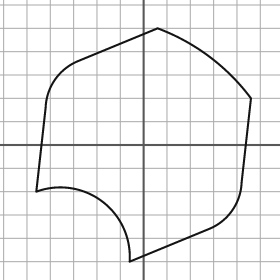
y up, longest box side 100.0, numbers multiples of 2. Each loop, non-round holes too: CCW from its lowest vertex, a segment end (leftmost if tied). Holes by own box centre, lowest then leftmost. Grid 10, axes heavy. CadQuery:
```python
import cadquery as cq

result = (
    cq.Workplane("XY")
    .moveTo(-6.0, -50.0)
    .lineTo(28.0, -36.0)
    .threePointArc((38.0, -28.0), (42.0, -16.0))
    .lineTo(46.0, 20.0)
    .threePointArc((28.0, 38.0), (6.0, 50.0))
    .lineTo(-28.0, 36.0)
    .threePointArc((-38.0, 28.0), (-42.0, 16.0))
    .lineTo(-46.0, -20.0)
    .threePointArc((-18.0, -24.0), (-6.0, -50.0))
    .close()
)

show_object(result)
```